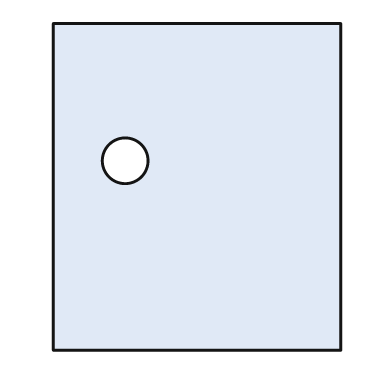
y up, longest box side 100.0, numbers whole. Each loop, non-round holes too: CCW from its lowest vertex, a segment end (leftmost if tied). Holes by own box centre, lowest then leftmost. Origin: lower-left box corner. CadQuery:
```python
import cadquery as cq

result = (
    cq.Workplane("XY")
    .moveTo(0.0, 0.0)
    .lineTo(88.0, 0.0)
    .lineTo(88.0, 100.0)
    .lineTo(0.0, 100.0)
    .close()
    .moveTo(22.0, 58.0)
    .circle(7.0)
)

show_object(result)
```